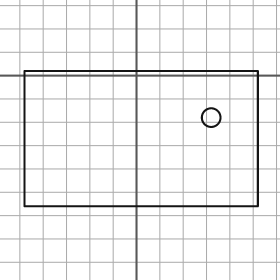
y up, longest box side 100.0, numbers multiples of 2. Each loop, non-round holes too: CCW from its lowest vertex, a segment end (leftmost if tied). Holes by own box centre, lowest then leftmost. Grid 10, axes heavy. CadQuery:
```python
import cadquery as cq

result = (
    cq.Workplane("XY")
    .moveTo(-48.0, -56.0)
    .lineTo(52.0, -56.0)
    .lineTo(52.0, 2.0)
    .lineTo(-48.0, 2.0)
    .close()
    .moveTo(32.0, -18.0)
    .circle(4.0)
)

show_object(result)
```